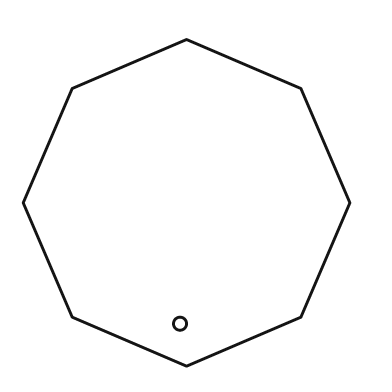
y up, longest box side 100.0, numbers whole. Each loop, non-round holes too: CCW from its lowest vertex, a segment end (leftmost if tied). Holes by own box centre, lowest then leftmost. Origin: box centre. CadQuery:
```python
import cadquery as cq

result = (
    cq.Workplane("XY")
    .moveTo(0.0, -50.0)
    .lineTo(35.0, -35.0)
    .lineTo(50.0, 0.0)
    .lineTo(35.0, 35.0)
    .lineTo(0.0, 50.0)
    .lineTo(-35.0, 35.0)
    .lineTo(-50.0, 0.0)
    .lineTo(-35.0, -35.0)
    .close()
    .moveTo(-2.0, -37.0)
    .circle(2.0)
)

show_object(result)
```